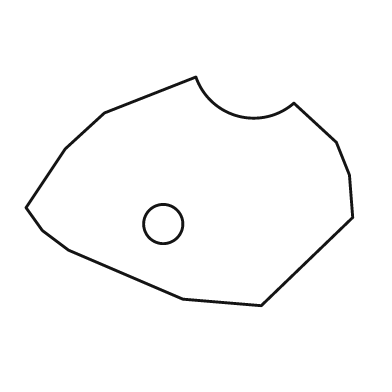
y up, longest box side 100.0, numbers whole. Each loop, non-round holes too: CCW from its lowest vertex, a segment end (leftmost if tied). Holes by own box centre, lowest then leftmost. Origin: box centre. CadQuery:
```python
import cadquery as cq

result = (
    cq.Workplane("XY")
    .moveTo(22.0, -35.0)
    .lineTo(50.0, -8.0)
    .lineTo(49.0, 5.0)
    .lineTo(45.0, 15.0)
    .lineTo(32.0, 27.0)
    .threePointArc((15.0, 23.0), (2.0, 35.0))
    .lineTo(-26.0, 24.0)
    .lineTo(-38.0, 13.0)
    .lineTo(-50.0, -5.0)
    .lineTo(-45.0, -12.0)
    .lineTo(-37.0, -18.0)
    .lineTo(-2.0, -33.0)
    .close()
    .moveTo(-8.0, -10.0)
    .circle(6.0)
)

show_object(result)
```